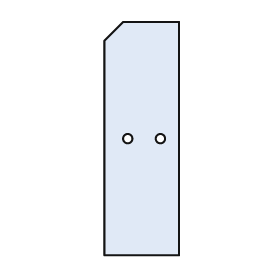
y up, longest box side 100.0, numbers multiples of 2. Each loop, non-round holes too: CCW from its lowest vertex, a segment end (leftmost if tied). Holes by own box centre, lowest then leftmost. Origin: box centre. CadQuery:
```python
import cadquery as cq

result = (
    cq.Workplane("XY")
    .moveTo(-16.0, -50.0)
    .lineTo(16.0, -50.0)
    .lineTo(16.0, 50.0)
    .lineTo(-8.0, 50.0)
    .lineTo(-16.0, 42.0)
    .close()
    .moveTo(-6.0, 0.0)
    .circle(2.0)
    .moveTo(8.0, 0.0)
    .circle(2.0)
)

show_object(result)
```